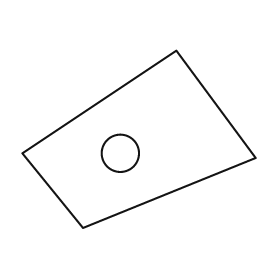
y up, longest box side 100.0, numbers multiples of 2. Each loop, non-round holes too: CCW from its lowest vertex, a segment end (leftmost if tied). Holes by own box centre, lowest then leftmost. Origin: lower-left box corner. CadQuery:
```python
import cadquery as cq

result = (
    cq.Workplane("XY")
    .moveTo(26.0, 0.0)
    .lineTo(100.0, 30.0)
    .lineTo(66.0, 76.0)
    .lineTo(0.0, 32.0)
    .close()
    .moveTo(42.0, 32.0)
    .circle(8.0)
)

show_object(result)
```